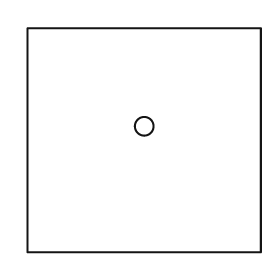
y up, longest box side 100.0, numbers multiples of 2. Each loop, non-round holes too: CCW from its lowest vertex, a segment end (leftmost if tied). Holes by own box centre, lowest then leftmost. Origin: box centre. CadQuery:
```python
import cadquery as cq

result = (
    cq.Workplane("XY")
    .moveTo(-50.0, -48.0)
    .lineTo(50.0, -48.0)
    .lineTo(50.0, 48.0)
    .lineTo(-50.0, 48.0)
    .close()
    .moveTo(0.0, 6.0)
    .circle(4.0)
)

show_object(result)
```